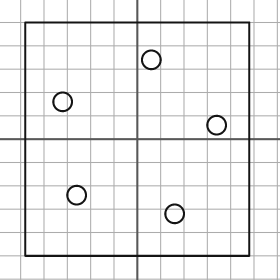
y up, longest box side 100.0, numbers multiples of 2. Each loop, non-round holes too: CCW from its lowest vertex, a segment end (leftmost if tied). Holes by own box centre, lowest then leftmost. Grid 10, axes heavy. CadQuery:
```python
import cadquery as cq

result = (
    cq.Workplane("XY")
    .moveTo(-48.0, -50.0)
    .lineTo(48.0, -50.0)
    .lineTo(48.0, 50.0)
    .lineTo(-48.0, 50.0)
    .close()
    .moveTo(16.0, -32.0)
    .circle(4.0)
    .moveTo(-26.0, -24.0)
    .circle(4.0)
    .moveTo(34.0, 6.0)
    .circle(4.0)
    .moveTo(-32.0, 16.0)
    .circle(4.0)
    .moveTo(6.0, 34.0)
    .circle(4.0)
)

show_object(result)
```